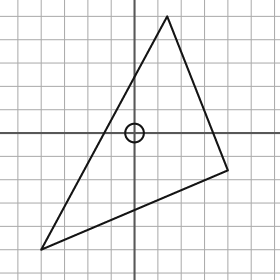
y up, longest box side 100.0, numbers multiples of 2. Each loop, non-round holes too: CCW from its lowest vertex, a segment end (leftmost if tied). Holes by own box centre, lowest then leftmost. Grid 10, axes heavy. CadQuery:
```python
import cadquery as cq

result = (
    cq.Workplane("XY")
    .moveTo(-40.0, -50.0)
    .lineTo(40.0, -16.0)
    .lineTo(14.0, 50.0)
    .close()
    .moveTo(0.0, 0.0)
    .circle(4.0)
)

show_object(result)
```